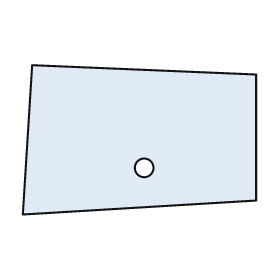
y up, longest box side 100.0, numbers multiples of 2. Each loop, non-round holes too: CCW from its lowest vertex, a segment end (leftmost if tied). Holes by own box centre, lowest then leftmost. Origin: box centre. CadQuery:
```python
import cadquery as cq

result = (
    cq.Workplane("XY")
    .moveTo(-50.0, -32.0)
    .lineTo(50.0, -26.0)
    .lineTo(50.0, 28.0)
    .lineTo(-46.0, 32.0)
    .close()
    .moveTo(2.0, -12.0)
    .circle(4.0)
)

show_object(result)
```